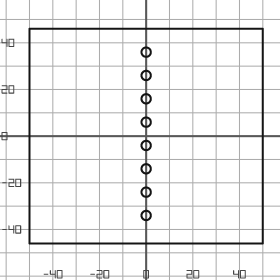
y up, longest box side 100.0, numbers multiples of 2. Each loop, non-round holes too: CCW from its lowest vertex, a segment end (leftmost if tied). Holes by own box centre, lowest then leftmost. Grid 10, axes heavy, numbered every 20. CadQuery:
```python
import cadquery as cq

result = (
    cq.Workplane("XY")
    .moveTo(-50.0, -46.0)
    .lineTo(50.0, -46.0)
    .lineTo(50.0, 46.0)
    .lineTo(-50.0, 46.0)
    .close()
    .moveTo(0.0, -34.0)
    .circle(2.0)
    .moveTo(0.0, -24.0)
    .circle(2.0)
    .moveTo(0.0, -14.0)
    .circle(2.0)
    .moveTo(0.0, -4.0)
    .circle(2.0)
    .moveTo(0.0, 6.0)
    .circle(2.0)
    .moveTo(0.0, 16.0)
    .circle(2.0)
    .moveTo(0.0, 26.0)
    .circle(2.0)
    .moveTo(0.0, 36.0)
    .circle(2.0)
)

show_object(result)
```